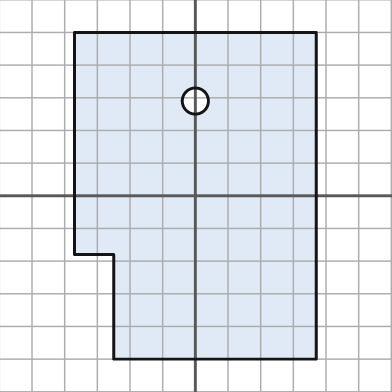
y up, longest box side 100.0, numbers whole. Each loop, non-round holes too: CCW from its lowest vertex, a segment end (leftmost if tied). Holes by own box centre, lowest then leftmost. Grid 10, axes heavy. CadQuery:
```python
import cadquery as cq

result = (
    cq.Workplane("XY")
    .moveTo(-25.0, -50.0)
    .lineTo(37.0, -50.0)
    .lineTo(37.0, 50.0)
    .lineTo(-37.0, 50.0)
    .lineTo(-37.0, -18.0)
    .lineTo(-25.0, -18.0)
    .close()
    .moveTo(0.0, 29.0)
    .circle(4.0)
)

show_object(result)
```